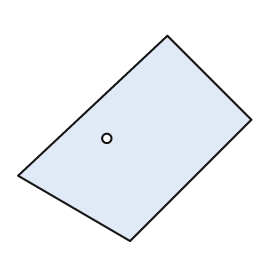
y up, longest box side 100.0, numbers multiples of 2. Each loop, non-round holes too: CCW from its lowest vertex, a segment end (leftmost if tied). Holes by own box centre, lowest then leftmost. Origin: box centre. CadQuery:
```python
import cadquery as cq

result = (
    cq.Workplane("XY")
    .moveTo(-2.0, -44.0)
    .lineTo(50.0, 8.0)
    .lineTo(14.0, 44.0)
    .lineTo(-50.0, -16.0)
    .close()
    .moveTo(-12.0, 0.0)
    .circle(2.0)
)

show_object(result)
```